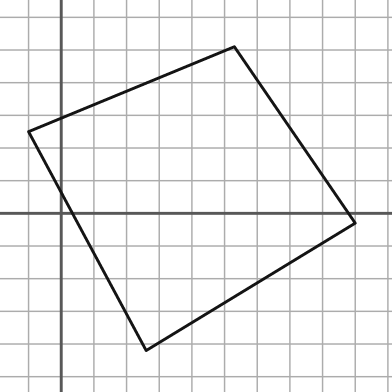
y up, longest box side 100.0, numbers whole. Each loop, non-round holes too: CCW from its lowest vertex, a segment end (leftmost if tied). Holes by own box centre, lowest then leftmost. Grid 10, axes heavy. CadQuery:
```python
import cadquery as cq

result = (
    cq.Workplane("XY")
    .moveTo(26.0, -42.0)
    .lineTo(90.0, -3.0)
    .lineTo(53.0, 51.0)
    .lineTo(-10.0, 25.0)
    .close()
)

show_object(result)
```